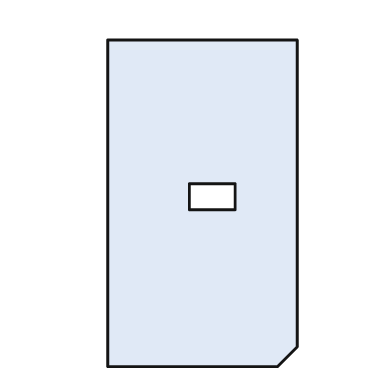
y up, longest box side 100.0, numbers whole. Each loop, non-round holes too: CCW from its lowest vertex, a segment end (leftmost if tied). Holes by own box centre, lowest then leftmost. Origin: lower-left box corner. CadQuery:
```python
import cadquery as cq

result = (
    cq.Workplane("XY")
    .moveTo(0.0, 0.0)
    .lineTo(52.0, 0.0)
    .lineTo(58.0, 6.0)
    .lineTo(58.0, 100.0)
    .lineTo(0.0, 100.0)
    .close()
    .moveTo(25.0, 48.0)
    .lineTo(39.0, 48.0)
    .lineTo(39.0, 56.0)
    .lineTo(25.0, 56.0)
    .close()
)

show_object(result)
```